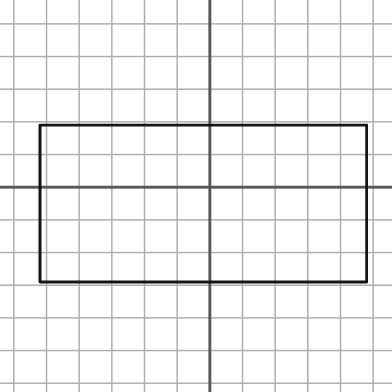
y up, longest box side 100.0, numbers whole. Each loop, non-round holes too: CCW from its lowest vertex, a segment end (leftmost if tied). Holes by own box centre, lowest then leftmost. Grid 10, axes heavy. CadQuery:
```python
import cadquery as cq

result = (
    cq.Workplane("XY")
    .moveTo(-52.0, -29.0)
    .lineTo(48.0, -29.0)
    .lineTo(48.0, 19.0)
    .lineTo(-52.0, 19.0)
    .close()
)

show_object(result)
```